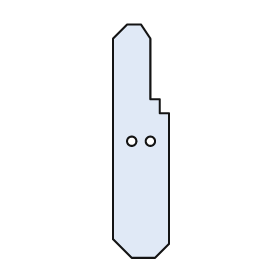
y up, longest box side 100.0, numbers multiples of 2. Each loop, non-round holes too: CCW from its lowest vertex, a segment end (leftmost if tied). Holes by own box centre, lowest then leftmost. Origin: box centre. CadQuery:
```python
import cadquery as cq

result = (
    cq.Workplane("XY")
    .moveTo(-4.0, -50.0)
    .lineTo(6.0, -50.0)
    .lineTo(12.0, -44.0)
    .lineTo(12.0, 12.0)
    .lineTo(8.0, 12.0)
    .lineTo(8.0, 18.0)
    .lineTo(4.0, 18.0)
    .lineTo(4.0, 44.0)
    .lineTo(0.0, 50.0)
    .lineTo(-6.0, 50.0)
    .lineTo(-12.0, 44.0)
    .lineTo(-12.0, -42.0)
    .close()
    .moveTo(-4.0, 0.0)
    .circle(2.0)
    .moveTo(4.0, 0.0)
    .circle(2.0)
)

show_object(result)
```